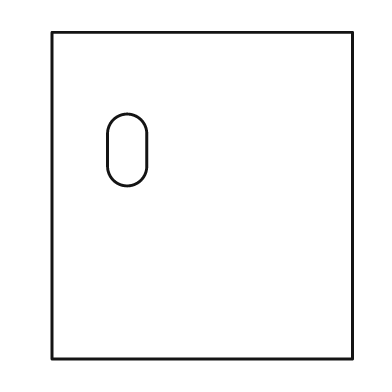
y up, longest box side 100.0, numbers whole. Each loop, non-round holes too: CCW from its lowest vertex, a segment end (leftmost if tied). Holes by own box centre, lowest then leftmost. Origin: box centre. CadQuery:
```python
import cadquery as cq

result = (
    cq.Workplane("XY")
    .moveTo(-46.0, -50.0)
    .lineTo(46.0, -50.0)
    .lineTo(46.0, 50.0)
    .lineTo(-46.0, 50.0)
    .close()
    .moveTo(-29.0, 9.0)
    .threePointArc((-23.0, 3.0), (-17.0, 9.0))
    .lineTo(-17.0, 19.0)
    .threePointArc((-23.0, 25.0), (-29.0, 19.0))
    .close()
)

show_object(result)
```